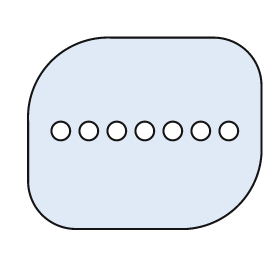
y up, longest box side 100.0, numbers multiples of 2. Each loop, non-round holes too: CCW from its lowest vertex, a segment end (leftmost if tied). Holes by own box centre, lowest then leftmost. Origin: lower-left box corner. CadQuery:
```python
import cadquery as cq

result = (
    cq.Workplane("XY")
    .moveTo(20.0, 0.0)
    .lineTo(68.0, 0.0)
    .threePointArc((90.0, 10.0), (100.0, 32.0))
    .lineTo(100.0, 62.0)
    .threePointArc((94.0, 76.0), (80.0, 82.0))
    .lineTo(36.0, 82.0)
    .threePointArc((10.0, 72.0), (0.0, 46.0))
    .lineTo(0.0, 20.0)
    .threePointArc((6.0, 6.0), (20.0, 0.0))
    .close()
    .moveTo(14.0, 42.0)
    .circle(4.0)
    .moveTo(26.0, 42.0)
    .circle(4.0)
    .moveTo(38.0, 42.0)
    .circle(4.0)
    .moveTo(50.0, 42.0)
    .circle(4.0)
    .moveTo(62.0, 42.0)
    .circle(4.0)
    .moveTo(74.0, 42.0)
    .circle(4.0)
    .moveTo(86.0, 42.0)
    .circle(4.0)
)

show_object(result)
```